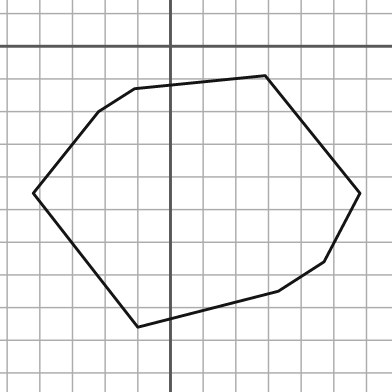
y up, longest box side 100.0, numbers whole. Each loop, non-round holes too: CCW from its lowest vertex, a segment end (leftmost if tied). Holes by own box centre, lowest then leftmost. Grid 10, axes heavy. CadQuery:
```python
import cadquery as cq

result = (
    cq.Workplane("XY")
    .moveTo(-10.0, -86.0)
    .lineTo(33.0, -75.0)
    .lineTo(47.0, -66.0)
    .lineTo(58.0, -45.0)
    .lineTo(29.0, -9.0)
    .lineTo(-11.0, -13.0)
    .lineTo(-22.0, -20.0)
    .lineTo(-42.0, -45.0)
    .close()
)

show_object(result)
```